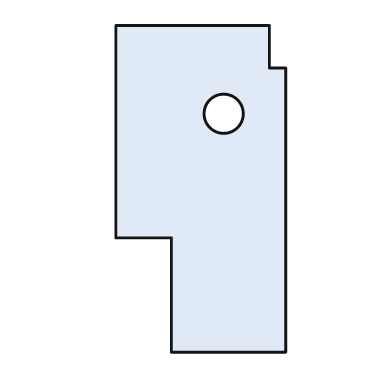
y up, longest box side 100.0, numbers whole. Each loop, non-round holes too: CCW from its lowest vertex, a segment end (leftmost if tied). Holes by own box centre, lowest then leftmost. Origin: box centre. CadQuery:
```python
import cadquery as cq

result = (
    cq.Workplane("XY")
    .moveTo(-9.0, -50.0)
    .lineTo(26.0, -50.0)
    .lineTo(26.0, 37.0)
    .lineTo(21.0, 37.0)
    .lineTo(21.0, 50.0)
    .lineTo(-26.0, 50.0)
    .lineTo(-26.0, -15.0)
    .lineTo(-9.0, -15.0)
    .close()
    .moveTo(7.0, 23.0)
    .circle(6.0)
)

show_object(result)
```